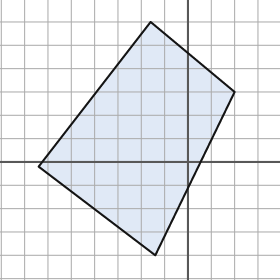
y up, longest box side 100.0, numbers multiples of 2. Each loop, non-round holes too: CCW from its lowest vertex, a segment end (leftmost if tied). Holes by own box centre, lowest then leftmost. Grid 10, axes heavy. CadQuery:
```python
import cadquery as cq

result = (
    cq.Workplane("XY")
    .moveTo(-14.0, -40.0)
    .lineTo(20.0, 30.0)
    .lineTo(-16.0, 60.0)
    .lineTo(-64.0, -2.0)
    .close()
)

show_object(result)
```